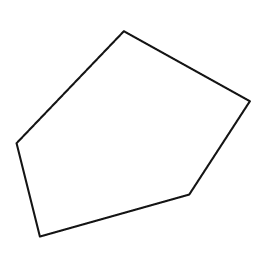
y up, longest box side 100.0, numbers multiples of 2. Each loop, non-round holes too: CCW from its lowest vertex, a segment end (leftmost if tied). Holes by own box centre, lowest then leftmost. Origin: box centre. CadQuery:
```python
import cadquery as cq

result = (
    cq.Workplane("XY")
    .moveTo(-40.0, -44.0)
    .lineTo(24.0, -26.0)
    .lineTo(50.0, 14.0)
    .lineTo(-4.0, 44.0)
    .lineTo(-50.0, -4.0)
    .close()
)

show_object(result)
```